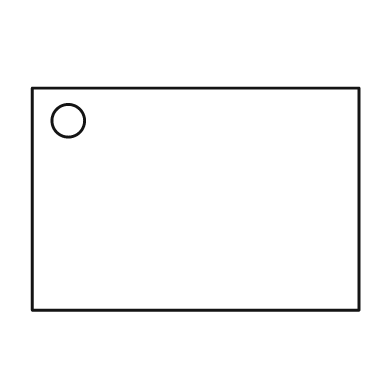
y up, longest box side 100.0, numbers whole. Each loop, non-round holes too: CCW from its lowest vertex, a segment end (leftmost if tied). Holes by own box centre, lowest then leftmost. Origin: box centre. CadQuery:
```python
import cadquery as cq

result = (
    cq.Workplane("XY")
    .moveTo(-50.0, -34.0)
    .lineTo(50.0, -34.0)
    .lineTo(50.0, 34.0)
    .lineTo(-50.0, 34.0)
    .close()
    .moveTo(-39.0, 24.0)
    .circle(5.0)
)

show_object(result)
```